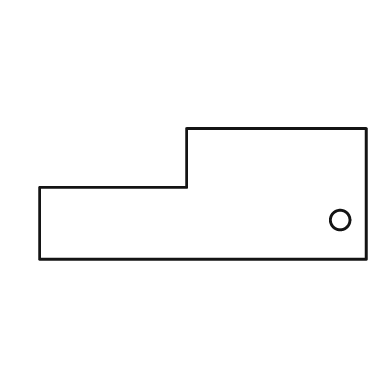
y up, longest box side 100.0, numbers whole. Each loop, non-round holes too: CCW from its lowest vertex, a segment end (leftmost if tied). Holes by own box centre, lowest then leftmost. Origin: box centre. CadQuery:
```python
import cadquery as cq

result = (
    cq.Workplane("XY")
    .moveTo(-50.0, -20.0)
    .lineTo(50.0, -20.0)
    .lineTo(50.0, 20.0)
    .lineTo(-5.0, 20.0)
    .lineTo(-5.0, 2.0)
    .lineTo(-50.0, 2.0)
    .close()
    .moveTo(42.0, -8.0)
    .circle(3.0)
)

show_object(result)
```